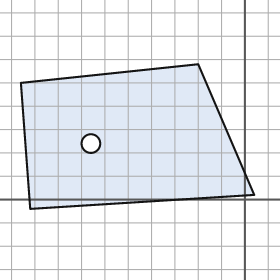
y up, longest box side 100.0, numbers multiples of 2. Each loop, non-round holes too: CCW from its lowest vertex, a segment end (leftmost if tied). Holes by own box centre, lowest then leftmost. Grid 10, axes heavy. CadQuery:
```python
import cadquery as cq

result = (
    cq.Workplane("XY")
    .moveTo(-92.0, -4.0)
    .lineTo(4.0, 2.0)
    .lineTo(-20.0, 58.0)
    .lineTo(-96.0, 50.0)
    .close()
    .moveTo(-66.0, 24.0)
    .circle(4.0)
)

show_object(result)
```